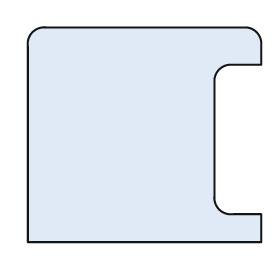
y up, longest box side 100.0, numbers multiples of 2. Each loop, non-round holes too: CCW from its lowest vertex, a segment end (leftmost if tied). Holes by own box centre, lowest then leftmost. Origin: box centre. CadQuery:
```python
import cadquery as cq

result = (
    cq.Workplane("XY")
    .moveTo(-50.0, -46.0)
    .lineTo(50.0, -46.0)
    .lineTo(50.0, -34.0)
    .lineTo(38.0, -34.0)
    .threePointArc((32.0, -32.0), (30.0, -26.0))
    .lineTo(30.0, 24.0)
    .threePointArc((32.0, 28.0), (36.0, 30.0))
    .lineTo(50.0, 30.0)
    .lineTo(50.0, 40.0)
    .threePointArc((48.0, 44.0), (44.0, 46.0))
    .lineTo(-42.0, 46.0)
    .threePointArc((-48.0, 44.0), (-50.0, 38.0))
    .close()
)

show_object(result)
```